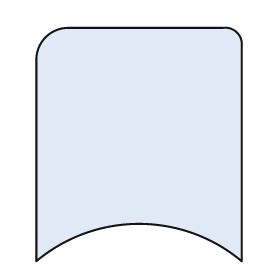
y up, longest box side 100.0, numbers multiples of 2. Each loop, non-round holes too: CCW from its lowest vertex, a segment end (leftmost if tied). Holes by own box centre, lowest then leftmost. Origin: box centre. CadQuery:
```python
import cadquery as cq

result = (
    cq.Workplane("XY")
    .moveTo(-44.0, -50.0)
    .threePointArc((0.0, -34.0), (44.0, -50.0))
    .lineTo(44.0, 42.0)
    .threePointArc((42.0, 48.0), (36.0, 50.0))
    .lineTo(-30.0, 50.0)
    .threePointArc((-40.0, 46.0), (-44.0, 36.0))
    .close()
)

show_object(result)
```